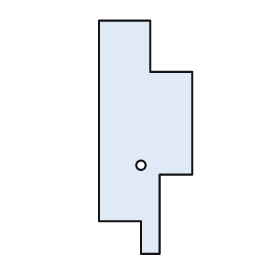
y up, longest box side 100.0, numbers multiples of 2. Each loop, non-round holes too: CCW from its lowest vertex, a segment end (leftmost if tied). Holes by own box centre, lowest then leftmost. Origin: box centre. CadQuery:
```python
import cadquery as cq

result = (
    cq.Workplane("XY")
    .moveTo(-2.0, -50.0)
    .lineTo(6.0, -50.0)
    .lineTo(6.0, -16.0)
    .lineTo(20.0, -16.0)
    .lineTo(20.0, 28.0)
    .lineTo(2.0, 28.0)
    .lineTo(2.0, 50.0)
    .lineTo(-20.0, 50.0)
    .lineTo(-20.0, -36.0)
    .lineTo(-2.0, -36.0)
    .close()
    .moveTo(-2.0, -12.0)
    .circle(2.0)
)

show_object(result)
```